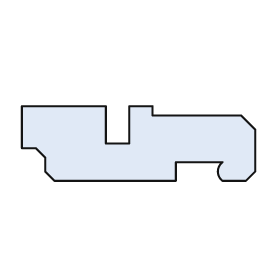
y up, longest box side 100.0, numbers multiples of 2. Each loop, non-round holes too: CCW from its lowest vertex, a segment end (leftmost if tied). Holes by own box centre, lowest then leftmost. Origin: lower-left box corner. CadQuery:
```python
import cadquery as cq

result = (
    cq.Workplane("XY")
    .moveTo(14.0, 0.0)
    .lineTo(66.0, 0.0)
    .lineTo(66.0, 8.0)
    .lineTo(86.0, 8.0)
    .threePointArc((84.0, 4.0), (86.0, 0.0))
    .lineTo(96.0, 0.0)
    .lineTo(100.0, 4.0)
    .lineTo(100.0, 22.0)
    .lineTo(94.0, 28.0)
    .lineTo(56.0, 28.0)
    .lineTo(56.0, 32.0)
    .lineTo(46.0, 32.0)
    .lineTo(46.0, 16.0)
    .lineTo(36.0, 16.0)
    .lineTo(36.0, 32.0)
    .lineTo(0.0, 32.0)
    .lineTo(0.0, 14.0)
    .lineTo(6.0, 14.0)
    .lineTo(10.0, 10.0)
    .lineTo(10.0, 4.0)
    .close()
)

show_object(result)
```